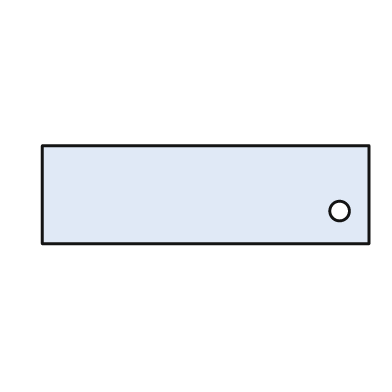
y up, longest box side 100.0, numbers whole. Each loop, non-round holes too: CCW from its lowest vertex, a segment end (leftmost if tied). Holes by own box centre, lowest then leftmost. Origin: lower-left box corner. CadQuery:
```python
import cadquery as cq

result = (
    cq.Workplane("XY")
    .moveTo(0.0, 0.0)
    .lineTo(100.0, 0.0)
    .lineTo(100.0, 30.0)
    .lineTo(0.0, 30.0)
    .close()
    .moveTo(91.0, 10.0)
    .circle(3.0)
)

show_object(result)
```